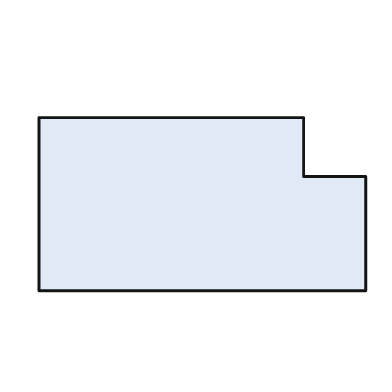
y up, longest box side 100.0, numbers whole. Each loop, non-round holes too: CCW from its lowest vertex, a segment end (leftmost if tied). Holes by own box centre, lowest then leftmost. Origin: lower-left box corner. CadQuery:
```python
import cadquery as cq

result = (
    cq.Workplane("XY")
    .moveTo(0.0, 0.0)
    .lineTo(100.0, 0.0)
    .lineTo(100.0, 35.0)
    .lineTo(81.0, 35.0)
    .lineTo(81.0, 53.0)
    .lineTo(0.0, 53.0)
    .close()
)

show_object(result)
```